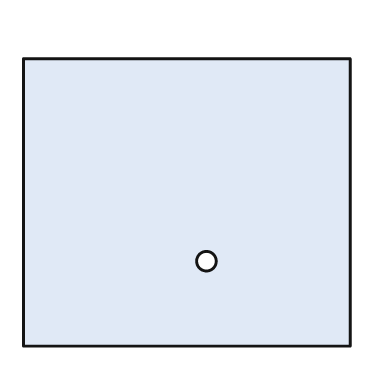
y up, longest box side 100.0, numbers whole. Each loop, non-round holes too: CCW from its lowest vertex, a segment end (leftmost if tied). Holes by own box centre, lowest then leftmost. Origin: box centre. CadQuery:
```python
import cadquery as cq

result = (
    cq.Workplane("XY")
    .moveTo(-50.0, -44.0)
    .lineTo(50.0, -44.0)
    .lineTo(50.0, 44.0)
    .lineTo(-50.0, 44.0)
    .close()
    .moveTo(6.0, -18.0)
    .circle(3.0)
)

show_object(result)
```